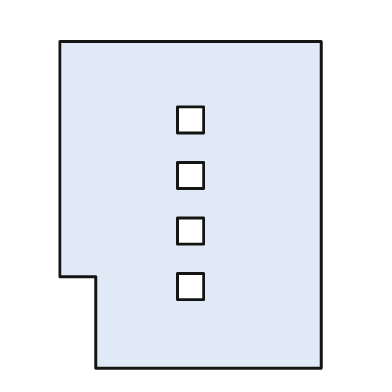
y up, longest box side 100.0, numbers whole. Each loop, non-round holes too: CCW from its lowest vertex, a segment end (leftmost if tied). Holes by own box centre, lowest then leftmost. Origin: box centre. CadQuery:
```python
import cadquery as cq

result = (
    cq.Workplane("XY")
    .moveTo(-29.0, -50.0)
    .lineTo(40.0, -50.0)
    .lineTo(40.0, 50.0)
    .lineTo(-40.0, 50.0)
    .lineTo(-40.0, -22.0)
    .lineTo(-29.0, -22.0)
    .close()
    .moveTo(-4.0, -29.0)
    .lineTo(4.0, -29.0)
    .lineTo(4.0, -21.0)
    .lineTo(-4.0, -21.0)
    .close()
    .moveTo(-4.0, -12.0)
    .lineTo(4.0, -12.0)
    .lineTo(4.0, -4.0)
    .lineTo(-4.0, -4.0)
    .close()
    .moveTo(-4.0, 5.0)
    .lineTo(4.0, 5.0)
    .lineTo(4.0, 13.0)
    .lineTo(-4.0, 13.0)
    .close()
    .moveTo(-4.0, 22.0)
    .lineTo(4.0, 22.0)
    .lineTo(4.0, 30.0)
    .lineTo(-4.0, 30.0)
    .close()
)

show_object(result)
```